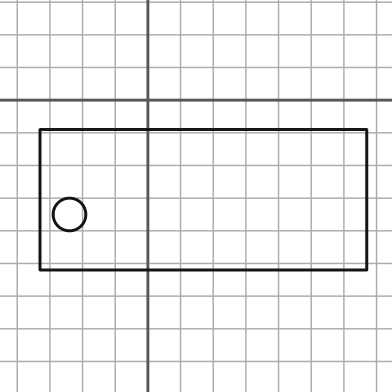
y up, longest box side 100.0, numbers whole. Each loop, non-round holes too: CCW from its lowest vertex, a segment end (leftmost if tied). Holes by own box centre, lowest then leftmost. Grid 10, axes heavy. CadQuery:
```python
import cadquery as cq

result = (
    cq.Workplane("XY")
    .moveTo(-33.0, -52.0)
    .lineTo(67.0, -52.0)
    .lineTo(67.0, -9.0)
    .lineTo(-33.0, -9.0)
    .close()
    .moveTo(-24.0, -35.0)
    .circle(5.0)
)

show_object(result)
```